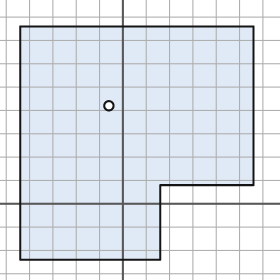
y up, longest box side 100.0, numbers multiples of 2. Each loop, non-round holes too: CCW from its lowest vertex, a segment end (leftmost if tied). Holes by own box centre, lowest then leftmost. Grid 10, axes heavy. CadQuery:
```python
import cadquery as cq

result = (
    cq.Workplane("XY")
    .moveTo(-44.0, -24.0)
    .lineTo(16.0, -24.0)
    .lineTo(16.0, 8.0)
    .lineTo(56.0, 8.0)
    .lineTo(56.0, 76.0)
    .lineTo(-44.0, 76.0)
    .close()
    .moveTo(-6.0, 42.0)
    .circle(2.0)
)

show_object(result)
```